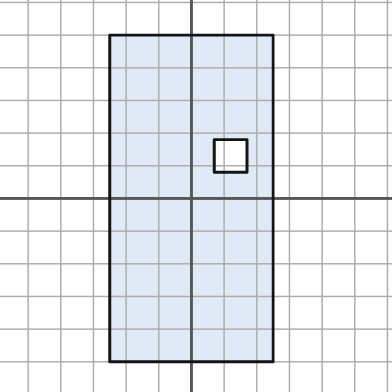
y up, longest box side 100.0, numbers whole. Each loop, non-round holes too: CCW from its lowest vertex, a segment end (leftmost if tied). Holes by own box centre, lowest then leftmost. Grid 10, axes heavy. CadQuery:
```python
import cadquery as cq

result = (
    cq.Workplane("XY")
    .moveTo(-25.0, -50.0)
    .lineTo(25.0, -50.0)
    .lineTo(25.0, 50.0)
    .lineTo(-25.0, 50.0)
    .close()
    .moveTo(7.0, 8.0)
    .lineTo(17.0, 8.0)
    .lineTo(17.0, 18.0)
    .lineTo(7.0, 18.0)
    .close()
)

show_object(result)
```